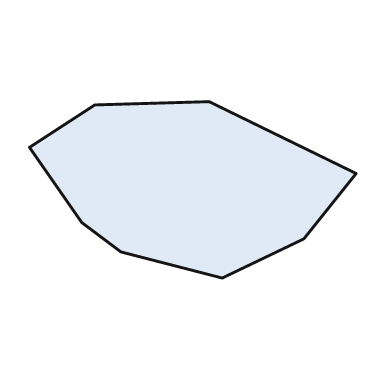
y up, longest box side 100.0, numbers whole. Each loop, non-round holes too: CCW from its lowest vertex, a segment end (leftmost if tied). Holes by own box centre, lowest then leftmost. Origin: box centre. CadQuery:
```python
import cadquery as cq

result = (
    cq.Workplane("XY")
    .moveTo(9.0, -27.0)
    .lineTo(34.0, -15.0)
    .lineTo(50.0, 5.0)
    .lineTo(5.0, 27.0)
    .lineTo(-30.0, 26.0)
    .lineTo(-50.0, 13.0)
    .lineTo(-34.0, -10.0)
    .lineTo(-22.0, -19.0)
    .close()
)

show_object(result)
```